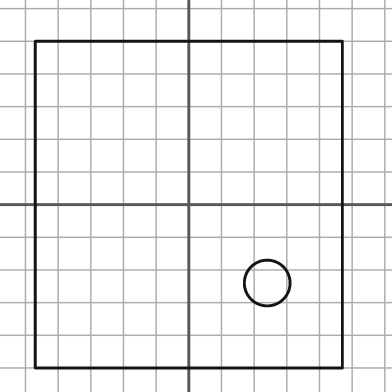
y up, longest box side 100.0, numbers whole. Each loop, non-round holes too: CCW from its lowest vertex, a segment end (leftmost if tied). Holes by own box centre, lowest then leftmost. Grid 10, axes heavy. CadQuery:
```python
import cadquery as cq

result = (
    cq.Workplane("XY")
    .moveTo(-47.0, -50.0)
    .lineTo(47.0, -50.0)
    .lineTo(47.0, 50.0)
    .lineTo(-47.0, 50.0)
    .close()
    .moveTo(24.0, -24.0)
    .circle(7.0)
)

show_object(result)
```